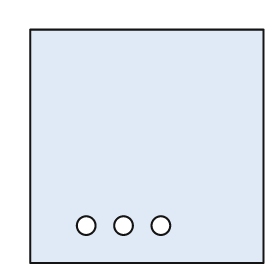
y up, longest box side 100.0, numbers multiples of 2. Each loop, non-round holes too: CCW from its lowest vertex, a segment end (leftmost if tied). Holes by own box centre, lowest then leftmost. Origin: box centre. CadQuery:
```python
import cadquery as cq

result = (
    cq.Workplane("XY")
    .moveTo(-50.0, -50.0)
    .lineTo(50.0, -50.0)
    .lineTo(50.0, 50.0)
    .lineTo(-50.0, 50.0)
    .close()
    .moveTo(-26.0, -34.0)
    .circle(4.0)
    .moveTo(-10.0, -34.0)
    .circle(4.0)
    .moveTo(6.0, -34.0)
    .circle(4.0)
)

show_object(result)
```